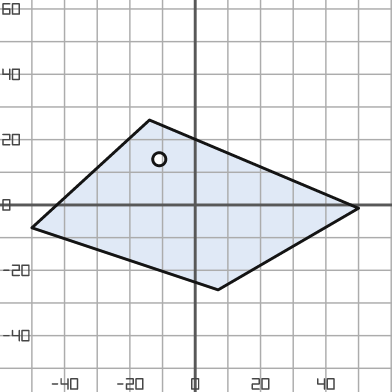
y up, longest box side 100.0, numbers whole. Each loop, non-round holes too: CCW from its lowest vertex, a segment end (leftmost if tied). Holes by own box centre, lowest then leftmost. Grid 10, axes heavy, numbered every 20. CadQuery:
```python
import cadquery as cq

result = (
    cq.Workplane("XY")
    .moveTo(7.0, -26.0)
    .lineTo(50.0, -1.0)
    .lineTo(-14.0, 26.0)
    .lineTo(-50.0, -7.0)
    .close()
    .moveTo(-11.0, 14.0)
    .circle(2.0)
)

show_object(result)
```